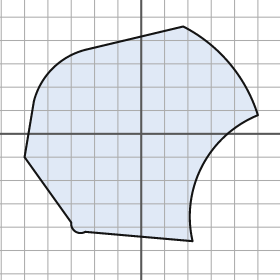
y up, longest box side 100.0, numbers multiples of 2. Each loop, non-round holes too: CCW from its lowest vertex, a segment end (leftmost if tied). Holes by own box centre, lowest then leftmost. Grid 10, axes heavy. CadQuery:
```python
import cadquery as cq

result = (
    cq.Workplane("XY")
    .moveTo(22.0, -46.0)
    .threePointArc((26.0, -14.0), (50.0, 8.0))
    .threePointArc((38.0, 30.0), (18.0, 46.0))
    .lineTo(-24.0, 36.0)
    .threePointArc((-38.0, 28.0), (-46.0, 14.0))
    .lineTo(-50.0, -10.0)
    .lineTo(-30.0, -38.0)
    .threePointArc((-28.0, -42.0), (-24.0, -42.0))
    .close()
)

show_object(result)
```